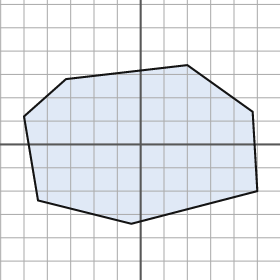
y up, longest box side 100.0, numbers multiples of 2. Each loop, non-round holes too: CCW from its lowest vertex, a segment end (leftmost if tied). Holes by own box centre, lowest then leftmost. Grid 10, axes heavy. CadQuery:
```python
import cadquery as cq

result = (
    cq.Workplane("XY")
    .moveTo(-4.0, -34.0)
    .lineTo(50.0, -20.0)
    .lineTo(48.0, 14.0)
    .lineTo(20.0, 34.0)
    .lineTo(-32.0, 28.0)
    .lineTo(-50.0, 12.0)
    .lineTo(-44.0, -24.0)
    .close()
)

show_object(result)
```